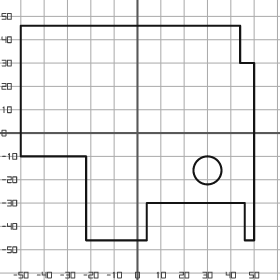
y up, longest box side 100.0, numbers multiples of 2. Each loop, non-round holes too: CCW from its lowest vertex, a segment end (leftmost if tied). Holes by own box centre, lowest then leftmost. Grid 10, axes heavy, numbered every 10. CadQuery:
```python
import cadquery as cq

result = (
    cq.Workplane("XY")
    .moveTo(-22.0, -46.0)
    .lineTo(4.0, -46.0)
    .lineTo(4.0, -30.0)
    .lineTo(46.0, -30.0)
    .lineTo(46.0, -46.0)
    .lineTo(50.0, -46.0)
    .lineTo(50.0, 30.0)
    .lineTo(44.0, 30.0)
    .lineTo(44.0, 46.0)
    .lineTo(-50.0, 46.0)
    .lineTo(-50.0, -10.0)
    .lineTo(-22.0, -10.0)
    .close()
    .moveTo(30.0, -16.0)
    .circle(6.0)
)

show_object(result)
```